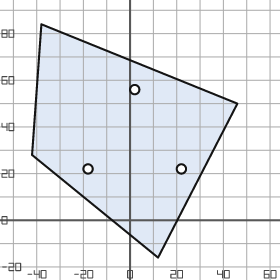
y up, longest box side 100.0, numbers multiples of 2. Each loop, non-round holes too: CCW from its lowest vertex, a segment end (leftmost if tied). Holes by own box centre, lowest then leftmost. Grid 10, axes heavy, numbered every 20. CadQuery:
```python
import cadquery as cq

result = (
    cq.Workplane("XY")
    .moveTo(12.0, -16.0)
    .lineTo(46.0, 50.0)
    .lineTo(-38.0, 84.0)
    .lineTo(-42.0, 28.0)
    .close()
    .moveTo(-18.0, 22.0)
    .circle(2.0)
    .moveTo(22.0, 22.0)
    .circle(2.0)
    .moveTo(2.0, 56.0)
    .circle(2.0)
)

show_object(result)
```